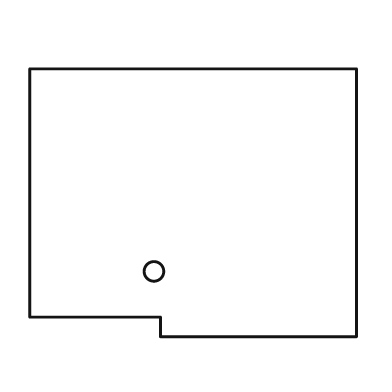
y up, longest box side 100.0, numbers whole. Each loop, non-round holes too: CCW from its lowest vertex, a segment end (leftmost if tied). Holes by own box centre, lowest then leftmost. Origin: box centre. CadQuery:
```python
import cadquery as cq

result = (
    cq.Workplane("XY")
    .moveTo(-10.0, -41.0)
    .lineTo(50.0, -41.0)
    .lineTo(50.0, 41.0)
    .lineTo(-50.0, 41.0)
    .lineTo(-50.0, -35.0)
    .lineTo(-10.0, -35.0)
    .close()
    .moveTo(-12.0, -21.0)
    .circle(3.0)
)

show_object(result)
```